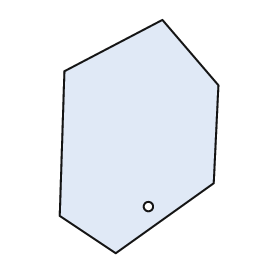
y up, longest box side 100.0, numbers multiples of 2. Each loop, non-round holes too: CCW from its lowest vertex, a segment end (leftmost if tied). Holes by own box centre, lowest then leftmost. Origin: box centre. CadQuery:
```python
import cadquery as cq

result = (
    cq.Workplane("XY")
    .moveTo(-10.0, -50.0)
    .lineTo(32.0, -20.0)
    .lineTo(34.0, 22.0)
    .lineTo(10.0, 50.0)
    .lineTo(-32.0, 28.0)
    .lineTo(-34.0, -34.0)
    .close()
    .moveTo(4.0, -30.0)
    .circle(2.0)
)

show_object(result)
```